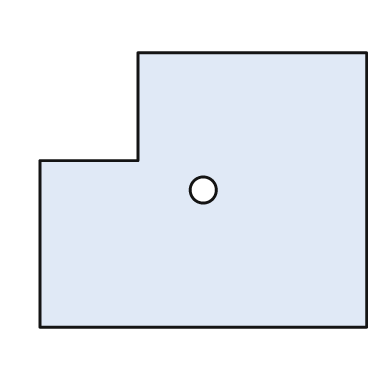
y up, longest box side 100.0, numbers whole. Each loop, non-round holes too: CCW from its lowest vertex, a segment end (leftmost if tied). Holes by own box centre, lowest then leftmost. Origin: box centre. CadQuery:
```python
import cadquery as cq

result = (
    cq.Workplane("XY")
    .moveTo(-50.0, -42.0)
    .lineTo(50.0, -42.0)
    .lineTo(50.0, 42.0)
    .lineTo(-20.0, 42.0)
    .lineTo(-20.0, 9.0)
    .lineTo(-50.0, 9.0)
    .close()
    .moveTo(0.0, 0.0)
    .circle(4.0)
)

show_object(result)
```